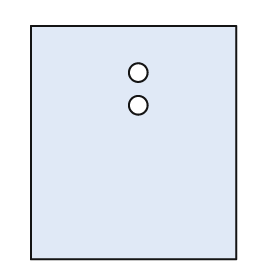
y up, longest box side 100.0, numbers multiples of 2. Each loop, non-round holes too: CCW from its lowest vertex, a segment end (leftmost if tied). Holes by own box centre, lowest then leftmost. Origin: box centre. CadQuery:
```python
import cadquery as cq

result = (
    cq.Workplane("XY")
    .moveTo(-44.0, -50.0)
    .lineTo(44.0, -50.0)
    .lineTo(44.0, 50.0)
    .lineTo(-44.0, 50.0)
    .close()
    .moveTo(2.0, 16.0)
    .circle(4.0)
    .moveTo(2.0, 30.0)
    .circle(4.0)
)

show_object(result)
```